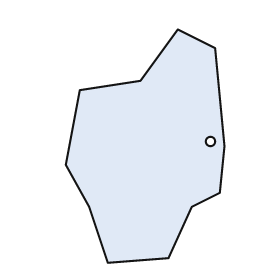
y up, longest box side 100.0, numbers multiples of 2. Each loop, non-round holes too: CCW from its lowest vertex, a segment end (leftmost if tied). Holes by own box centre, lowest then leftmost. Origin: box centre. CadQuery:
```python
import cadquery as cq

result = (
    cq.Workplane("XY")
    .moveTo(-16.0, -50.0)
    .lineTo(10.0, -48.0)
    .lineTo(20.0, -26.0)
    .lineTo(32.0, -20.0)
    .lineTo(34.0, 0.0)
    .lineTo(30.0, 42.0)
    .lineTo(14.0, 50.0)
    .lineTo(-2.0, 28.0)
    .lineTo(-28.0, 24.0)
    .lineTo(-34.0, -8.0)
    .lineTo(-24.0, -26.0)
    .close()
    .moveTo(28.0, 2.0)
    .circle(2.0)
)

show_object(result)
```